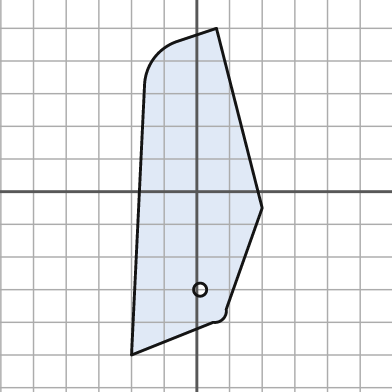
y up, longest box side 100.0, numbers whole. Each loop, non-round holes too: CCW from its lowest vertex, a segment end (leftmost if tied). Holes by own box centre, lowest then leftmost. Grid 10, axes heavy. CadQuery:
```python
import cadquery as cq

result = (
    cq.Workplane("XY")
    .moveTo(-20.0, -50.0)
    .lineTo(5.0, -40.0)
    .threePointArc((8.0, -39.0), (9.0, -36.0))
    .lineTo(20.0, -5.0)
    .lineTo(6.0, 50.0)
    .lineTo(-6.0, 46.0)
    .threePointArc((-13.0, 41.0), (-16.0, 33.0))
    .close()
    .moveTo(1.0, -30.0)
    .circle(2.0)
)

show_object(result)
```